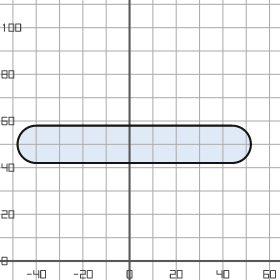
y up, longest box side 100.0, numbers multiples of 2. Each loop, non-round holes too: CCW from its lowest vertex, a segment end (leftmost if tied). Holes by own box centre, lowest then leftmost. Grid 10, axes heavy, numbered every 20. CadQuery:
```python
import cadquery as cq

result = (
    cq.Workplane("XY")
    .moveTo(-40.0, 42.0)
    .lineTo(44.0, 42.0)
    .threePointArc((52.0, 50.0), (44.0, 58.0))
    .lineTo(-40.0, 58.0)
    .threePointArc((-48.0, 50.0), (-40.0, 42.0))
    .close()
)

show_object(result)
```